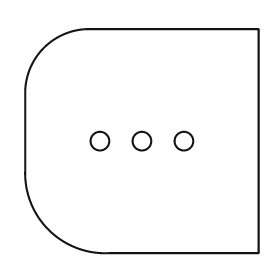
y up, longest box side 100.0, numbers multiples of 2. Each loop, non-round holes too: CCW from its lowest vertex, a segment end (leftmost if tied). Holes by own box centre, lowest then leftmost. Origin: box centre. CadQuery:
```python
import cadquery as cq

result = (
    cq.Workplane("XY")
    .moveTo(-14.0, -48.0)
    .lineTo(50.0, -48.0)
    .lineTo(50.0, 48.0)
    .lineTo(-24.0, 48.0)
    .threePointArc((-42.0, 40.0), (-50.0, 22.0))
    .lineTo(-50.0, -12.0)
    .threePointArc((-40.0, -38.0), (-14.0, -48.0))
    .close()
    .moveTo(-18.0, 0.0)
    .circle(4.0)
    .moveTo(0.0, 0.0)
    .circle(4.0)
    .moveTo(18.0, 0.0)
    .circle(4.0)
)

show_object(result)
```